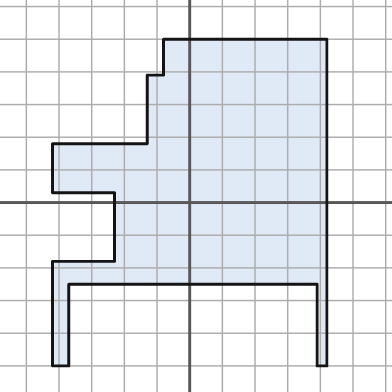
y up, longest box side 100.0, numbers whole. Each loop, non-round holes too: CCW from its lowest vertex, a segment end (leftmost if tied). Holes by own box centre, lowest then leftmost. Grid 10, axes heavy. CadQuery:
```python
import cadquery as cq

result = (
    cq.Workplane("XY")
    .moveTo(-42.0, -50.0)
    .lineTo(-37.0, -50.0)
    .lineTo(-37.0, -25.0)
    .lineTo(39.0, -25.0)
    .lineTo(39.0, -50.0)
    .lineTo(42.0, -50.0)
    .lineTo(42.0, 50.0)
    .lineTo(-8.0, 50.0)
    .lineTo(-8.0, 39.0)
    .lineTo(-13.0, 39.0)
    .lineTo(-13.0, 18.0)
    .lineTo(-42.0, 18.0)
    .lineTo(-42.0, 3.0)
    .lineTo(-23.0, 3.0)
    .lineTo(-23.0, -18.0)
    .lineTo(-42.0, -18.0)
    .close()
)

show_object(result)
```